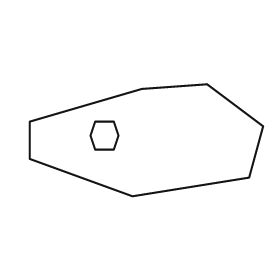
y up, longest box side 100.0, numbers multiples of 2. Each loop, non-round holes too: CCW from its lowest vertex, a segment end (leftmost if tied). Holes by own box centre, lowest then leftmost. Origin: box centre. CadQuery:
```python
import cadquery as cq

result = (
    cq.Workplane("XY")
    .moveTo(-6.0, -24.0)
    .lineTo(44.0, -16.0)
    .lineTo(50.0, 6.0)
    .lineTo(26.0, 24.0)
    .lineTo(-2.0, 22.0)
    .lineTo(-50.0, 8.0)
    .lineTo(-50.0, -8.0)
    .close()
    .moveTo(-22.0, -4.0)
    .lineTo(-14.0, -4.0)
    .lineTo(-12.0, 2.0)
    .lineTo(-14.0, 8.0)
    .lineTo(-22.0, 8.0)
    .lineTo(-24.0, 2.0)
    .close()
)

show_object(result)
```